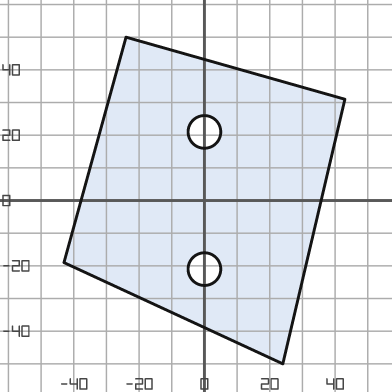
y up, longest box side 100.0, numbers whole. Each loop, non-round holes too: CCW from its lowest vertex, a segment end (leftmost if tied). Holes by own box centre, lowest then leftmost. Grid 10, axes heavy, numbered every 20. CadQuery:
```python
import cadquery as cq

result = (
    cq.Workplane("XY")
    .moveTo(24.0, -50.0)
    .lineTo(43.0, 31.0)
    .lineTo(-24.0, 50.0)
    .lineTo(-43.0, -19.0)
    .close()
    .moveTo(0.0, -21.0)
    .circle(5.0)
    .moveTo(0.0, 21.0)
    .circle(5.0)
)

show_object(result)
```